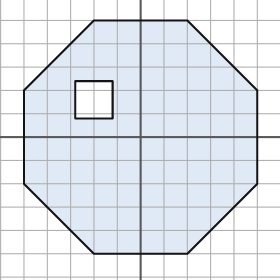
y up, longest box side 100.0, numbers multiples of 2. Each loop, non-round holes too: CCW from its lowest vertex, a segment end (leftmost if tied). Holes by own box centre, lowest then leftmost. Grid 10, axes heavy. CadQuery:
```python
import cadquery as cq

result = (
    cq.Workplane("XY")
    .moveTo(-20.0, -50.0)
    .lineTo(20.0, -50.0)
    .lineTo(50.0, -20.0)
    .lineTo(50.0, 20.0)
    .lineTo(20.0, 50.0)
    .lineTo(-20.0, 50.0)
    .lineTo(-50.0, 20.0)
    .lineTo(-50.0, -20.0)
    .close()
    .moveTo(-28.0, 8.0)
    .lineTo(-12.0, 8.0)
    .lineTo(-12.0, 24.0)
    .lineTo(-28.0, 24.0)
    .close()
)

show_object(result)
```